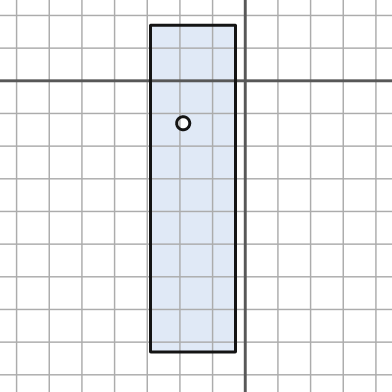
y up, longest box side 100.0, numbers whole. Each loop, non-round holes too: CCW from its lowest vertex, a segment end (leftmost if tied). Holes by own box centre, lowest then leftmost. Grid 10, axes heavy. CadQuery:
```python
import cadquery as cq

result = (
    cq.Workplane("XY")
    .moveTo(-29.0, -83.0)
    .lineTo(-3.0, -83.0)
    .lineTo(-3.0, 17.0)
    .lineTo(-29.0, 17.0)
    .close()
    .moveTo(-19.0, -13.0)
    .circle(2.0)
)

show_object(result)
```